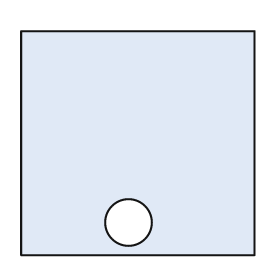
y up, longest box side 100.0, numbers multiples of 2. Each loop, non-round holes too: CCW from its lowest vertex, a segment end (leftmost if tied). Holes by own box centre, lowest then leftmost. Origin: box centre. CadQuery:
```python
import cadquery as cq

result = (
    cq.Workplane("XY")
    .moveTo(-50.0, -48.0)
    .lineTo(50.0, -48.0)
    .lineTo(50.0, 48.0)
    .lineTo(-50.0, 48.0)
    .close()
    .moveTo(-4.0, -34.0)
    .circle(10.0)
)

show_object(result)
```